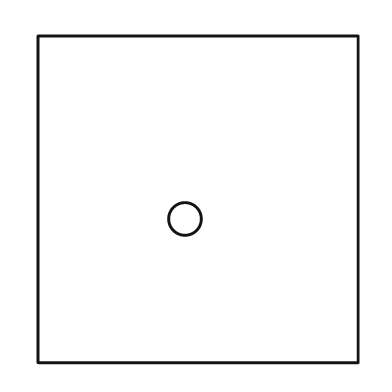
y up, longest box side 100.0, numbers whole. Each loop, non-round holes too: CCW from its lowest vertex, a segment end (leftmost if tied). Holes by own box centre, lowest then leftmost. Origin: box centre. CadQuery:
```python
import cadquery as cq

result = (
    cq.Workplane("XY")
    .moveTo(-49.0, -50.0)
    .lineTo(49.0, -50.0)
    .lineTo(49.0, 50.0)
    .lineTo(-49.0, 50.0)
    .close()
    .moveTo(-4.0, -6.0)
    .circle(5.0)
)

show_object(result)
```